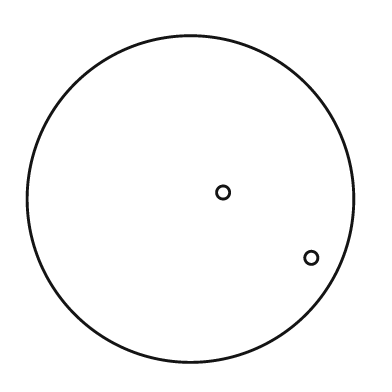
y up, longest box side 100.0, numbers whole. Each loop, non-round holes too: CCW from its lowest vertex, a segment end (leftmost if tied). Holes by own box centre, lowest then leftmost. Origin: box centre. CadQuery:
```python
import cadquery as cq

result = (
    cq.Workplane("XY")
    .moveTo(0.0, 0.0)
    .circle(50.0)
    .moveTo(37.0, -18.0)
    .circle(2.0)
    .moveTo(10.0, 2.0)
    .circle(2.0)
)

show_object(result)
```